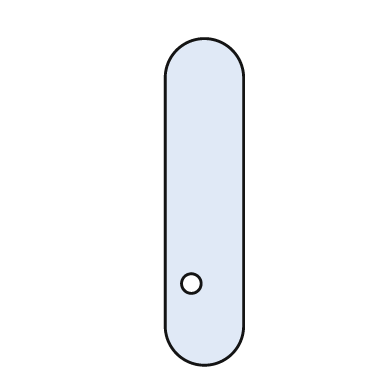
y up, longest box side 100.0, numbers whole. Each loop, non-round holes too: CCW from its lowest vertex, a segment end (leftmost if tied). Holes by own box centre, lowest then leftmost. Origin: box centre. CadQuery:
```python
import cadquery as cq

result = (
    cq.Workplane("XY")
    .moveTo(-12.0, -38.0)
    .threePointArc((0.0, -50.0), (12.0, -38.0))
    .lineTo(12.0, 38.0)
    .threePointArc((0.0, 50.0), (-12.0, 38.0))
    .close()
    .moveTo(-4.0, -25.0)
    .circle(3.0)
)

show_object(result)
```